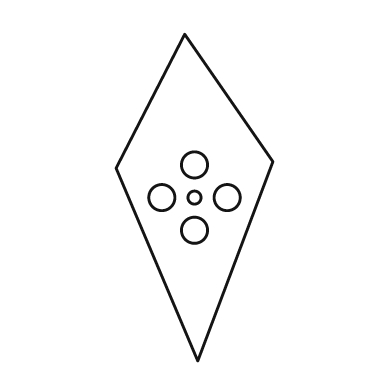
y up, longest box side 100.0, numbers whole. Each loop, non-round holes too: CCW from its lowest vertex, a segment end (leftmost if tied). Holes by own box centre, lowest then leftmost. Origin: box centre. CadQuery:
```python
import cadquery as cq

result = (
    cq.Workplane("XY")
    .moveTo(1.0, -50.0)
    .lineTo(24.0, 11.0)
    .lineTo(-3.0, 50.0)
    .lineTo(-24.0, 9.0)
    .close()
    .moveTo(0.0, -10.0)
    .circle(4.0)
    .moveTo(-10.0, 0.0)
    .circle(4.0)
    .moveTo(0.0, 0.0)
    .circle(2.0)
    .moveTo(10.0, 0.0)
    .circle(4.0)
    .moveTo(0.0, 10.0)
    .circle(4.0)
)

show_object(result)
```